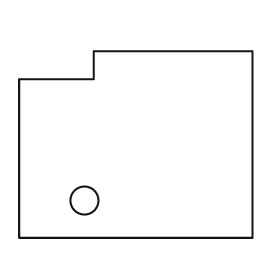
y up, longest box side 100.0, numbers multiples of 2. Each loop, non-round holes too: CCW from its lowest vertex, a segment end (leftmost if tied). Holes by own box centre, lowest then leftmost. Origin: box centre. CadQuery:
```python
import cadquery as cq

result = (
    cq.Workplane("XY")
    .moveTo(-50.0, -40.0)
    .lineTo(50.0, -40.0)
    .lineTo(50.0, 40.0)
    .lineTo(-18.0, 40.0)
    .lineTo(-18.0, 28.0)
    .lineTo(-50.0, 28.0)
    .close()
    .moveTo(-22.0, -24.0)
    .circle(6.0)
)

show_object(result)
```